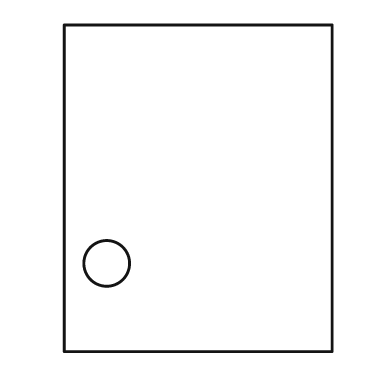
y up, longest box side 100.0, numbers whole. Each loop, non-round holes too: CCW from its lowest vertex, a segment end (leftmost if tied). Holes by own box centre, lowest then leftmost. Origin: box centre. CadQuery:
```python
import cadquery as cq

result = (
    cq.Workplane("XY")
    .moveTo(-41.0, -50.0)
    .lineTo(41.0, -50.0)
    .lineTo(41.0, 50.0)
    .lineTo(-41.0, 50.0)
    .close()
    .moveTo(-28.0, -23.0)
    .circle(7.0)
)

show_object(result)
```